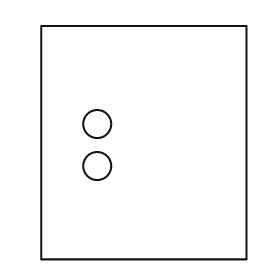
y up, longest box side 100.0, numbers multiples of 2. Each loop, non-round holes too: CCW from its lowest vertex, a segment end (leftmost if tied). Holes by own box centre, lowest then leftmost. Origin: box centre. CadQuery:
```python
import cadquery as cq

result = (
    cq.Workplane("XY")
    .moveTo(-44.0, -50.0)
    .lineTo(44.0, -50.0)
    .lineTo(44.0, 50.0)
    .lineTo(-44.0, 50.0)
    .close()
    .moveTo(-20.0, -10.0)
    .circle(6.0)
    .moveTo(-20.0, 8.0)
    .circle(6.0)
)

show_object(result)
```